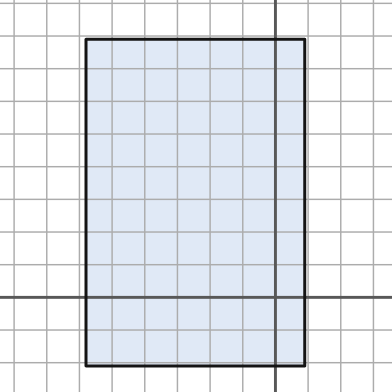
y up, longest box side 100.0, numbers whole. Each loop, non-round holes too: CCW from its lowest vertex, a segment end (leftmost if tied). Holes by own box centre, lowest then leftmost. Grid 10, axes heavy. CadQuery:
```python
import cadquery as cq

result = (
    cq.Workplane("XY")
    .moveTo(-58.0, -21.0)
    .lineTo(9.0, -21.0)
    .lineTo(9.0, 79.0)
    .lineTo(-58.0, 79.0)
    .close()
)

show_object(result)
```